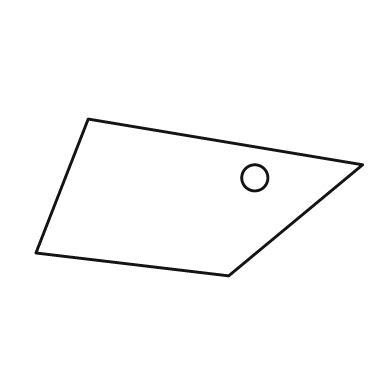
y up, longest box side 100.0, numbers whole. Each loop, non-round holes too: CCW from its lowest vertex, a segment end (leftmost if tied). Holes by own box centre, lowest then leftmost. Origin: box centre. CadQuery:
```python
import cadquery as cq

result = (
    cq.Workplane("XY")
    .moveTo(9.0, -24.0)
    .lineTo(50.0, 10.0)
    .lineTo(-34.0, 24.0)
    .lineTo(-50.0, -17.0)
    .close()
    .moveTo(17.0, 6.0)
    .circle(4.0)
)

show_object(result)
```